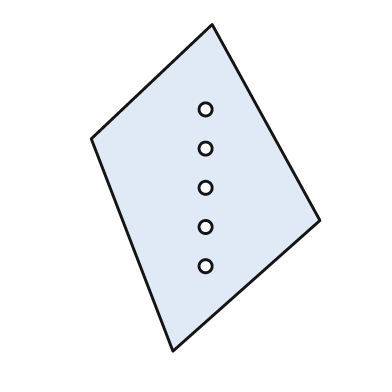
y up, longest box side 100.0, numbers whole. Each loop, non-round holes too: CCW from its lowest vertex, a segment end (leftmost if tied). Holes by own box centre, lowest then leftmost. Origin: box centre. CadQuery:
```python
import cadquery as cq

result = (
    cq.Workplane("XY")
    .moveTo(-10.0, -50.0)
    .lineTo(35.0, -10.0)
    .lineTo(2.0, 50.0)
    .lineTo(-35.0, 15.0)
    .close()
    .moveTo(0.0, -24.0)
    .circle(2.0)
    .moveTo(0.0, -12.0)
    .circle(2.0)
    .moveTo(0.0, 0.0)
    .circle(2.0)
    .moveTo(0.0, 12.0)
    .circle(2.0)
    .moveTo(0.0, 24.0)
    .circle(2.0)
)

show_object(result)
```